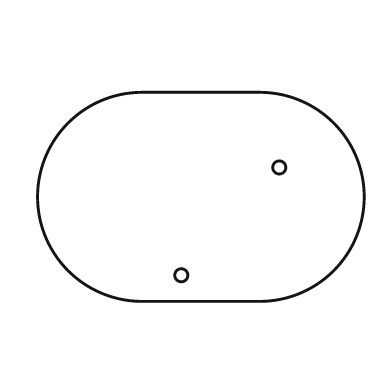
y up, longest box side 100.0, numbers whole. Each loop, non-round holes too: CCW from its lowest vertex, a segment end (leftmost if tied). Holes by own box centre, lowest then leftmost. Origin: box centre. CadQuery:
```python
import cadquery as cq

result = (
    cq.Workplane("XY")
    .moveTo(-18.0, -32.0)
    .lineTo(18.0, -32.0)
    .threePointArc((50.0, 0.0), (18.0, 32.0))
    .lineTo(-18.0, 32.0)
    .threePointArc((-50.0, 0.0), (-18.0, -32.0))
    .close()
    .moveTo(-6.0, -24.0)
    .circle(2.0)
    .moveTo(24.0, 9.0)
    .circle(2.0)
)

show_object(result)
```